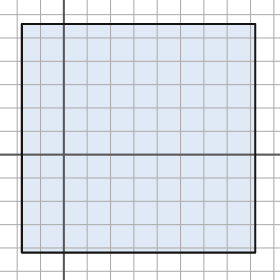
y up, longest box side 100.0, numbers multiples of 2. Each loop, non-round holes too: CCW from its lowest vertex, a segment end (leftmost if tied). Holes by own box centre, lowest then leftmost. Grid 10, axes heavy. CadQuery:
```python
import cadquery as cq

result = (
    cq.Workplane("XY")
    .moveTo(-18.0, -42.0)
    .lineTo(82.0, -42.0)
    .lineTo(82.0, 56.0)
    .lineTo(-18.0, 56.0)
    .close()
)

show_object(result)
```